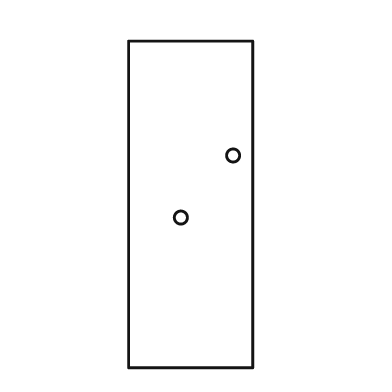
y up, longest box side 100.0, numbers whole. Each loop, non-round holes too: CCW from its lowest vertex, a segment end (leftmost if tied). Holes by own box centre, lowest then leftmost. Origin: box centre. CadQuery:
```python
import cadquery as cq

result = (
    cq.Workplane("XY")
    .moveTo(-19.0, -50.0)
    .lineTo(19.0, -50.0)
    .lineTo(19.0, 50.0)
    .lineTo(-19.0, 50.0)
    .close()
    .moveTo(-3.0, -4.0)
    .circle(2.0)
    .moveTo(13.0, 15.0)
    .circle(2.0)
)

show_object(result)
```